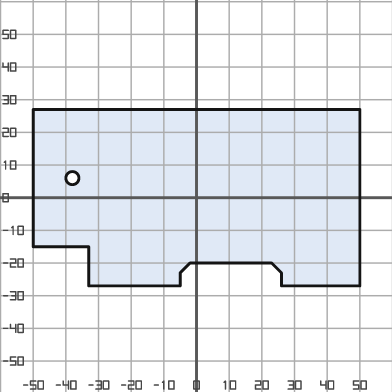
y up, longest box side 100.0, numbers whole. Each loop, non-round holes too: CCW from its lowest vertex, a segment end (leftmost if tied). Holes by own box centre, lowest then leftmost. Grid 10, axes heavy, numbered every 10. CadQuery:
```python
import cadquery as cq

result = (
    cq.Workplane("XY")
    .moveTo(-33.0, -27.0)
    .lineTo(-5.0, -27.0)
    .lineTo(-5.0, -23.0)
    .lineTo(-2.0, -20.0)
    .lineTo(23.0, -20.0)
    .lineTo(26.0, -23.0)
    .lineTo(26.0, -27.0)
    .lineTo(50.0, -27.0)
    .lineTo(50.0, 27.0)
    .lineTo(-50.0, 27.0)
    .lineTo(-50.0, -15.0)
    .lineTo(-33.0, -15.0)
    .close()
    .moveTo(-38.0, 6.0)
    .circle(2.0)
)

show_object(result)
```